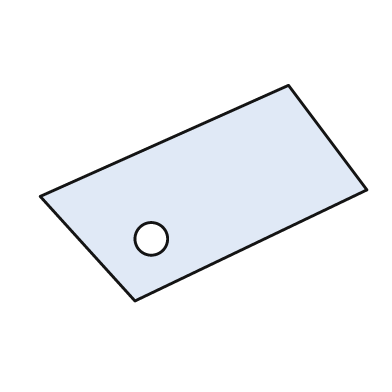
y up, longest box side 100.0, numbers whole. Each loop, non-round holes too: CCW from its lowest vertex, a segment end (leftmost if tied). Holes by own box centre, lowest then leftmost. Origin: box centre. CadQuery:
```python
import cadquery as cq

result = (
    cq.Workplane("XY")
    .moveTo(-21.0, -33.0)
    .lineTo(50.0, 1.0)
    .lineTo(26.0, 33.0)
    .lineTo(-50.0, -1.0)
    .close()
    .moveTo(-16.0, -14.0)
    .circle(5.0)
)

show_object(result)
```